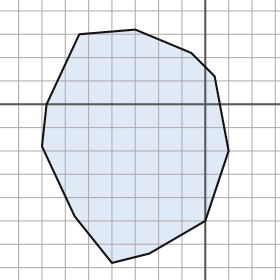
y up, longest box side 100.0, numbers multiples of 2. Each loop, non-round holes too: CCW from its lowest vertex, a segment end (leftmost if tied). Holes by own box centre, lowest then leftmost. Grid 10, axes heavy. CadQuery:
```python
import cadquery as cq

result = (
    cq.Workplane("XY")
    .moveTo(-40.0, -68.0)
    .lineTo(-24.0, -64.0)
    .lineTo(0.0, -50.0)
    .lineTo(10.0, -20.0)
    .lineTo(4.0, 12.0)
    .lineTo(-6.0, 22.0)
    .lineTo(-30.0, 32.0)
    .lineTo(-54.0, 30.0)
    .lineTo(-68.0, 0.0)
    .lineTo(-70.0, -18.0)
    .lineTo(-56.0, -48.0)
    .close()
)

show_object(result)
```